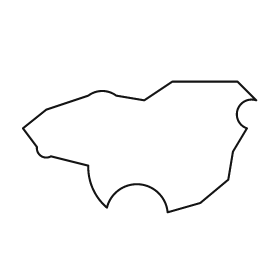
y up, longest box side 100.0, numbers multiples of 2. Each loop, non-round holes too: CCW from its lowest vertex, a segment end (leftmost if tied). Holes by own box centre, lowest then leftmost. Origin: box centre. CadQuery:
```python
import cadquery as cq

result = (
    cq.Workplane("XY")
    .moveTo(12.0, -28.0)
    .lineTo(26.0, -24.0)
    .lineTo(38.0, -14.0)
    .lineTo(40.0, -2.0)
    .lineTo(46.0, 8.0)
    .threePointArc((42.0, 16.0), (50.0, 20.0))
    .lineTo(42.0, 28.0)
    .lineTo(14.0, 28.0)
    .lineTo(2.0, 20.0)
    .lineTo(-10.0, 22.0)
    .threePointArc((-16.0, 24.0), (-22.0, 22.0))
    .lineTo(-40.0, 16.0)
    .lineTo(-50.0, 8.0)
    .lineTo(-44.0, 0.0)
    .threePointArc((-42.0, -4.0), (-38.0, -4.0))
    .lineTo(-22.0, -8.0)
    .threePointArc((-20.0, -18.0), (-14.0, -26.0))
    .threePointArc((0.0, -16.0), (12.0, -28.0))
    .close()
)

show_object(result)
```